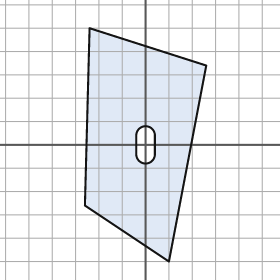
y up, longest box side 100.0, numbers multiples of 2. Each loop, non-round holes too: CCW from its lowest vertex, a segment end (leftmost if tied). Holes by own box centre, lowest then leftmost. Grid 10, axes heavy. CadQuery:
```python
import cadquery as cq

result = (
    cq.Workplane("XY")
    .moveTo(10.0, -50.0)
    .lineTo(26.0, 34.0)
    .lineTo(-24.0, 50.0)
    .lineTo(-26.0, -26.0)
    .close()
    .moveTo(-4.0, -4.0)
    .threePointArc((0.0, -8.0), (4.0, -4.0))
    .lineTo(4.0, 4.0)
    .threePointArc((0.0, 8.0), (-4.0, 4.0))
    .close()
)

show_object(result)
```